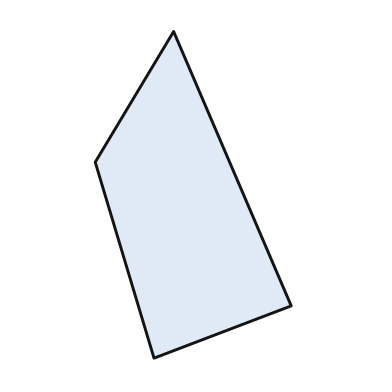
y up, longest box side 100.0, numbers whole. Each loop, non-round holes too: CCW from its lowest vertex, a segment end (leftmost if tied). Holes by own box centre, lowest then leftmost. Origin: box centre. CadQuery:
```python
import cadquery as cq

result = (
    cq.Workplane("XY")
    .moveTo(-12.0, -50.0)
    .lineTo(30.0, -34.0)
    .lineTo(-6.0, 50.0)
    .lineTo(-30.0, 10.0)
    .close()
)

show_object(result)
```